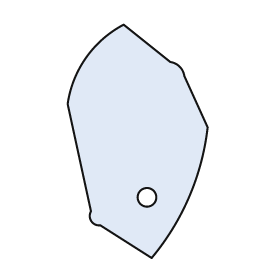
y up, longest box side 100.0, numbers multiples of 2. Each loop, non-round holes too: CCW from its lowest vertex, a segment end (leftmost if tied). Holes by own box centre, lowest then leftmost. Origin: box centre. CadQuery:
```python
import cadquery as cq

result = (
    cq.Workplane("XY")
    .moveTo(6.0, -50.0)
    .threePointArc((22.0, -24.0), (30.0, 6.0))
    .lineTo(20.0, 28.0)
    .threePointArc((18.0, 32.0), (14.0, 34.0))
    .lineTo(-6.0, 50.0)
    .threePointArc((-22.0, 36.0), (-30.0, 16.0))
    .lineTo(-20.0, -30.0)
    .threePointArc((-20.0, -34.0), (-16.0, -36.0))
    .close()
    .moveTo(4.0, -24.0)
    .circle(4.0)
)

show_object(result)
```